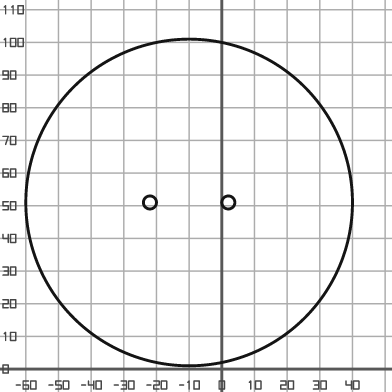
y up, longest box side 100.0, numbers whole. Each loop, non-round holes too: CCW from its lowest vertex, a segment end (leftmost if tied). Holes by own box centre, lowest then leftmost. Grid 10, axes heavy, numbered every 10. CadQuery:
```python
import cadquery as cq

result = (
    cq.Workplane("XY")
    .moveTo(-10.0, 51.0)
    .circle(50.0)
    .moveTo(-22.0, 51.0)
    .circle(2.0)
    .moveTo(2.0, 51.0)
    .circle(2.0)
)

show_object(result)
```